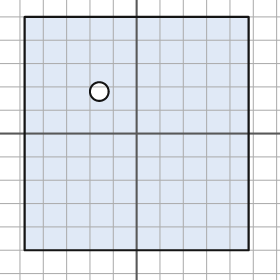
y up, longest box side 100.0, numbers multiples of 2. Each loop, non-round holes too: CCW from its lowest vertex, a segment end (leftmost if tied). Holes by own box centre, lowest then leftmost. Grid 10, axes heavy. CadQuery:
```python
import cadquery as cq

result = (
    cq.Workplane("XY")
    .moveTo(-48.0, -50.0)
    .lineTo(48.0, -50.0)
    .lineTo(48.0, 50.0)
    .lineTo(-48.0, 50.0)
    .close()
    .moveTo(-16.0, 18.0)
    .circle(4.0)
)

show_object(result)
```